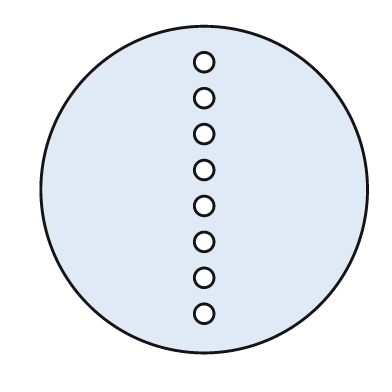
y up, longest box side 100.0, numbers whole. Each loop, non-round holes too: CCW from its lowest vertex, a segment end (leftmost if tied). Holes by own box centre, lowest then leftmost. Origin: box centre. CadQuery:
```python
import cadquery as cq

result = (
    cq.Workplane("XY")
    .moveTo(0.0, 0.0)
    .circle(50.0)
    .moveTo(0.0, -38.0)
    .circle(3.0)
    .moveTo(0.0, -27.0)
    .circle(3.0)
    .moveTo(0.0, -16.0)
    .circle(3.0)
    .moveTo(0.0, -5.0)
    .circle(3.0)
    .moveTo(0.0, 6.0)
    .circle(3.0)
    .moveTo(0.0, 17.0)
    .circle(3.0)
    .moveTo(0.0, 28.0)
    .circle(3.0)
    .moveTo(0.0, 39.0)
    .circle(3.0)
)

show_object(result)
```